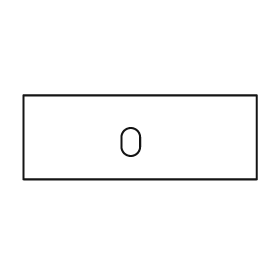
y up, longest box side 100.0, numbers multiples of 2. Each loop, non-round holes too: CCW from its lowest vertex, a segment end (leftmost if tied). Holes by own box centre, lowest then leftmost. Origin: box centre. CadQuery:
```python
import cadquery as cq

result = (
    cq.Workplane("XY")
    .moveTo(-50.0, -18.0)
    .lineTo(50.0, -18.0)
    .lineTo(50.0, 18.0)
    .lineTo(-50.0, 18.0)
    .close()
    .moveTo(-8.0, -4.0)
    .threePointArc((-4.0, -8.0), (0.0, -4.0))
    .lineTo(0.0, 0.0)
    .threePointArc((-4.0, 4.0), (-8.0, 0.0))
    .close()
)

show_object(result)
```